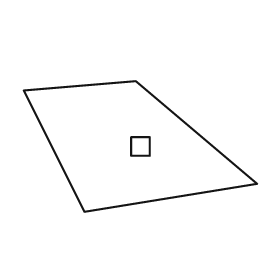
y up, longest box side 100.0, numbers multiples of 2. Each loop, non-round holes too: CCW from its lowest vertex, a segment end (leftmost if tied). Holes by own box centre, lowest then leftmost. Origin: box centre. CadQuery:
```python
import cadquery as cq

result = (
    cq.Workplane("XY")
    .moveTo(-24.0, -28.0)
    .lineTo(50.0, -16.0)
    .lineTo(-2.0, 28.0)
    .lineTo(-50.0, 24.0)
    .close()
    .moveTo(-4.0, -4.0)
    .lineTo(4.0, -4.0)
    .lineTo(4.0, 4.0)
    .lineTo(-4.0, 4.0)
    .close()
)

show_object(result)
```